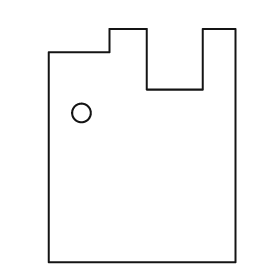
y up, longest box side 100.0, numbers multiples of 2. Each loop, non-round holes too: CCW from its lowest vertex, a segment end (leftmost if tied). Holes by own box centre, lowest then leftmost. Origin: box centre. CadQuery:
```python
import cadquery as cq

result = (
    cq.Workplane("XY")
    .moveTo(-40.0, -50.0)
    .lineTo(40.0, -50.0)
    .lineTo(40.0, 50.0)
    .lineTo(26.0, 50.0)
    .lineTo(26.0, 24.0)
    .lineTo(2.0, 24.0)
    .lineTo(2.0, 50.0)
    .lineTo(-14.0, 50.0)
    .lineTo(-14.0, 40.0)
    .lineTo(-40.0, 40.0)
    .close()
    .moveTo(-26.0, 14.0)
    .circle(4.0)
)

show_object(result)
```